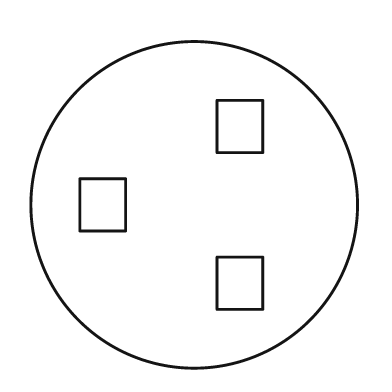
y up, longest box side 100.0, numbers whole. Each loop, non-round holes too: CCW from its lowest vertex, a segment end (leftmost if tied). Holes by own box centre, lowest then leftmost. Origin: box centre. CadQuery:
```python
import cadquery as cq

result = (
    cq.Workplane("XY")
    .moveTo(0.0, 0.0)
    .circle(50.0)
    .moveTo(7.0, -32.0)
    .lineTo(21.0, -32.0)
    .lineTo(21.0, -16.0)
    .lineTo(7.0, -16.0)
    .close()
    .moveTo(-35.0, -8.0)
    .lineTo(-21.0, -8.0)
    .lineTo(-21.0, 8.0)
    .lineTo(-35.0, 8.0)
    .close()
    .moveTo(7.0, 16.0)
    .lineTo(21.0, 16.0)
    .lineTo(21.0, 32.0)
    .lineTo(7.0, 32.0)
    .close()
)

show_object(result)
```